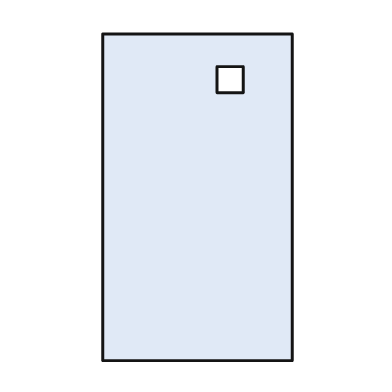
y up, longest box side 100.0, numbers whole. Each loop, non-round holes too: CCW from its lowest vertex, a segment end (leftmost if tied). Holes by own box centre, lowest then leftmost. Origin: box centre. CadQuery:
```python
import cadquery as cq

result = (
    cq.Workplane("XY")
    .moveTo(-29.0, -50.0)
    .lineTo(29.0, -50.0)
    .lineTo(29.0, 50.0)
    .lineTo(-29.0, 50.0)
    .close()
    .moveTo(6.0, 32.0)
    .lineTo(14.0, 32.0)
    .lineTo(14.0, 40.0)
    .lineTo(6.0, 40.0)
    .close()
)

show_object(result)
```